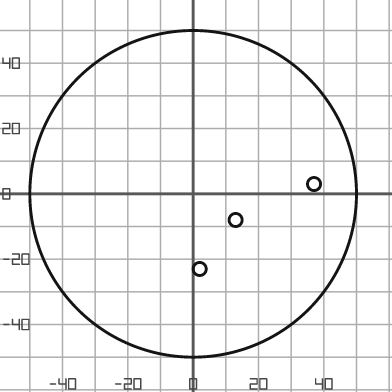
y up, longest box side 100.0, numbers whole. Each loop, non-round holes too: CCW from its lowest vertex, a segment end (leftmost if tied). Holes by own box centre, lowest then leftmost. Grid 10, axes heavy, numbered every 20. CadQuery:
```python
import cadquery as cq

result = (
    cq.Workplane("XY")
    .moveTo(0.0, 0.0)
    .circle(50.0)
    .moveTo(2.0, -23.0)
    .circle(2.0)
    .moveTo(13.0, -8.0)
    .circle(2.0)
    .moveTo(37.0, 3.0)
    .circle(2.0)
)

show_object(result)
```